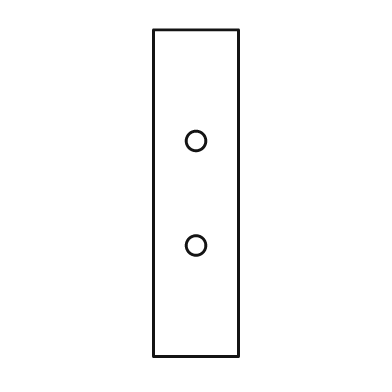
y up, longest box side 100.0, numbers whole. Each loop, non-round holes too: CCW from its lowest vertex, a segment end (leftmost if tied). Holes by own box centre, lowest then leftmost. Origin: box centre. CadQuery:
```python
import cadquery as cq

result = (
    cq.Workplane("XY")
    .moveTo(-13.0, -50.0)
    .lineTo(13.0, -50.0)
    .lineTo(13.0, 50.0)
    .lineTo(-13.0, 50.0)
    .close()
    .moveTo(0.0, -16.0)
    .circle(3.0)
    .moveTo(0.0, 16.0)
    .circle(3.0)
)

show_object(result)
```